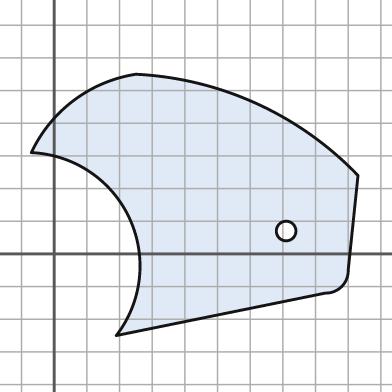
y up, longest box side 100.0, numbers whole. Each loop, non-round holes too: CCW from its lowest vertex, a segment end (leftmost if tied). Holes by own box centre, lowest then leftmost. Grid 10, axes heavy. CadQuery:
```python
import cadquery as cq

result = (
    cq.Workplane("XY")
    .moveTo(19.0, -25.0)
    .lineTo(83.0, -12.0)
    .threePointArc((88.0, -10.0), (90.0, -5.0))
    .lineTo(93.0, 24.0)
    .threePointArc((62.0, 46.0), (25.0, 55.0))
    .threePointArc((6.0, 47.0), (-7.0, 31.0))
    .threePointArc((23.0, 11.0), (19.0, -25.0))
    .close()
    .moveTo(71.0, 7.0)
    .circle(3.0)
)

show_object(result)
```